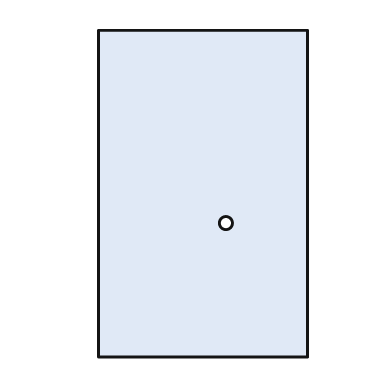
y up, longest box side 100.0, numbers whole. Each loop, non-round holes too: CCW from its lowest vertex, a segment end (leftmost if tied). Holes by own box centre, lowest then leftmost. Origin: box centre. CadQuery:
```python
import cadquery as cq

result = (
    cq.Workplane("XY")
    .moveTo(-32.0, -50.0)
    .lineTo(32.0, -50.0)
    .lineTo(32.0, 50.0)
    .lineTo(-32.0, 50.0)
    .close()
    .moveTo(7.0, -9.0)
    .circle(2.0)
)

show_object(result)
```